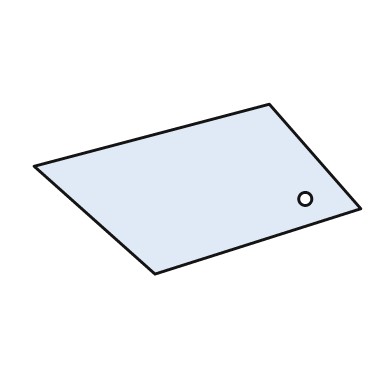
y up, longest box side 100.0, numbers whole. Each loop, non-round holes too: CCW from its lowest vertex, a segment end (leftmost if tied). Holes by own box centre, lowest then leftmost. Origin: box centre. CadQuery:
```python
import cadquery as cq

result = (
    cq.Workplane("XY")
    .moveTo(-13.0, -26.0)
    .lineTo(50.0, -6.0)
    .lineTo(22.0, 26.0)
    .lineTo(-50.0, 7.0)
    .close()
    .moveTo(33.0, -3.0)
    .circle(2.0)
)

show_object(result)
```